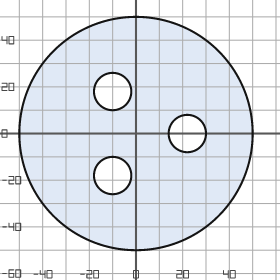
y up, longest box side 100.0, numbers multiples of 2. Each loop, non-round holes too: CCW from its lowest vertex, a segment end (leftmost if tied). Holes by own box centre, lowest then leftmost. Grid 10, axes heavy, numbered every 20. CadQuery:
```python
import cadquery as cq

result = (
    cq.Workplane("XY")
    .moveTo(0.0, 0.0)
    .circle(50.0)
    .moveTo(-10.0, -18.0)
    .circle(8.0)
    .moveTo(22.0, 0.0)
    .circle(8.0)
    .moveTo(-10.0, 18.0)
    .circle(8.0)
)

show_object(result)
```